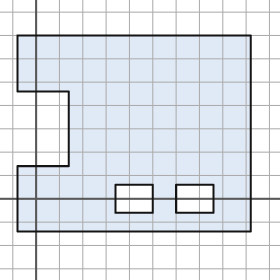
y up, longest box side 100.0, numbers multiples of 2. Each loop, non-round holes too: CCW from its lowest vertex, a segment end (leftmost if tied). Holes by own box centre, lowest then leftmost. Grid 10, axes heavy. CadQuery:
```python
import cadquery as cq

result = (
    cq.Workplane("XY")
    .moveTo(-8.0, -14.0)
    .lineTo(92.0, -14.0)
    .lineTo(92.0, 70.0)
    .lineTo(-8.0, 70.0)
    .lineTo(-8.0, 46.0)
    .lineTo(14.0, 46.0)
    .lineTo(14.0, 14.0)
    .lineTo(-8.0, 14.0)
    .close()
    .moveTo(34.0, -6.0)
    .lineTo(50.0, -6.0)
    .lineTo(50.0, 6.0)
    .lineTo(34.0, 6.0)
    .close()
    .moveTo(60.0, -6.0)
    .lineTo(76.0, -6.0)
    .lineTo(76.0, 6.0)
    .lineTo(60.0, 6.0)
    .close()
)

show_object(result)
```